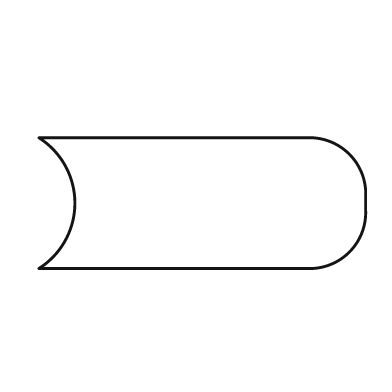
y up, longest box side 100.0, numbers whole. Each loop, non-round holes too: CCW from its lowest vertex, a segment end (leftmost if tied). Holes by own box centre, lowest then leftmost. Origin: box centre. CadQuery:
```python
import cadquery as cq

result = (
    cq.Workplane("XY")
    .moveTo(-50.0, -20.0)
    .lineTo(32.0, -20.0)
    .threePointArc((45.0, -15.0), (50.0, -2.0))
    .lineTo(50.0, 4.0)
    .threePointArc((45.0, 15.0), (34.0, 20.0))
    .lineTo(-50.0, 20.0)
    .threePointArc((-39.0, 0.0), (-50.0, -20.0))
    .close()
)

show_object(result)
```